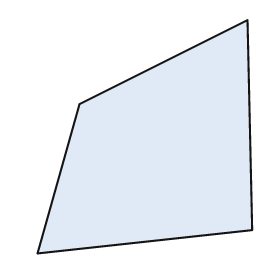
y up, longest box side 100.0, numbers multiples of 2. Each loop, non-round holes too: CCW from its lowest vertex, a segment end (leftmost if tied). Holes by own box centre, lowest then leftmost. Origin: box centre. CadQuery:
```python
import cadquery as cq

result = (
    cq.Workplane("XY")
    .moveTo(-46.0, -50.0)
    .lineTo(46.0, -40.0)
    .lineTo(44.0, 50.0)
    .lineTo(-28.0, 14.0)
    .close()
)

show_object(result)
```